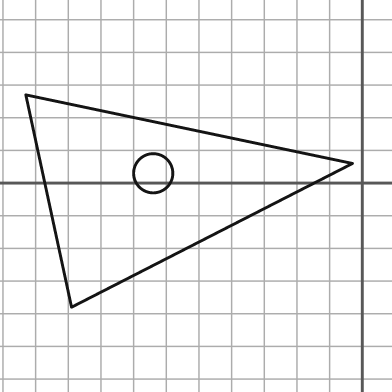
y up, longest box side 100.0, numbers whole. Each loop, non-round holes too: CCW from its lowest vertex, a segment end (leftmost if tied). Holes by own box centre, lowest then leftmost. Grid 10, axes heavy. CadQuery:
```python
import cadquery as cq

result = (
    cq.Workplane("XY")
    .moveTo(-89.0, -38.0)
    .lineTo(-3.0, 6.0)
    .lineTo(-103.0, 27.0)
    .close()
    .moveTo(-64.0, 3.0)
    .circle(6.0)
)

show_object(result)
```